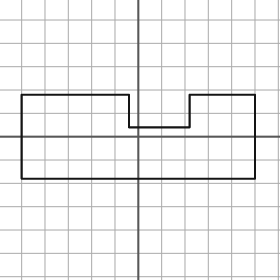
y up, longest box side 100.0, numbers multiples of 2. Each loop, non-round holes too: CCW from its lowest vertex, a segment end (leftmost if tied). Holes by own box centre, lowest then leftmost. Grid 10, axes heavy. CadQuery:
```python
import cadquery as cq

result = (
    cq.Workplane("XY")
    .moveTo(-50.0, -18.0)
    .lineTo(50.0, -18.0)
    .lineTo(50.0, 18.0)
    .lineTo(22.0, 18.0)
    .lineTo(22.0, 4.0)
    .lineTo(-4.0, 4.0)
    .lineTo(-4.0, 18.0)
    .lineTo(-50.0, 18.0)
    .close()
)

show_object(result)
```